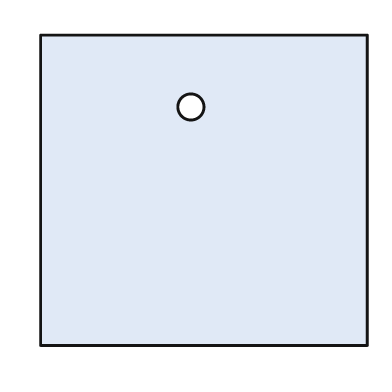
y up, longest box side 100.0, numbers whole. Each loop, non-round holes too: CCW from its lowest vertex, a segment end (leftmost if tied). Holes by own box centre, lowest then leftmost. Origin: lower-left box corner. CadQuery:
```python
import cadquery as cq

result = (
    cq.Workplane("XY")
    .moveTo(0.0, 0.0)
    .lineTo(100.0, 0.0)
    .lineTo(100.0, 95.0)
    .lineTo(0.0, 95.0)
    .close()
    .moveTo(46.0, 73.0)
    .circle(4.0)
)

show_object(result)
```